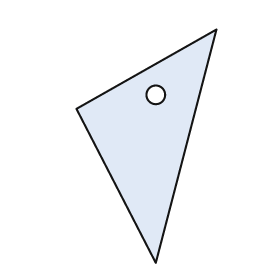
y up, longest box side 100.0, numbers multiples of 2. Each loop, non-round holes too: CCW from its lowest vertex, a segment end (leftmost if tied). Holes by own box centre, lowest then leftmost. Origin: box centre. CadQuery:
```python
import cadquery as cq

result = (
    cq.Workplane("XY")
    .moveTo(4.0, -50.0)
    .lineTo(30.0, 50.0)
    .lineTo(-30.0, 16.0)
    .close()
    .moveTo(4.0, 22.0)
    .circle(4.0)
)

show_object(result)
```